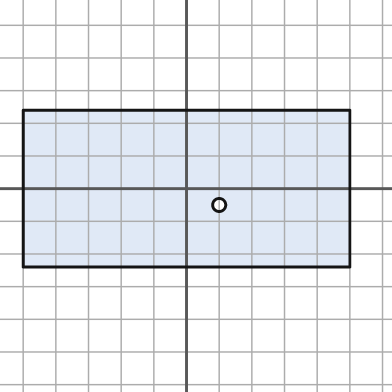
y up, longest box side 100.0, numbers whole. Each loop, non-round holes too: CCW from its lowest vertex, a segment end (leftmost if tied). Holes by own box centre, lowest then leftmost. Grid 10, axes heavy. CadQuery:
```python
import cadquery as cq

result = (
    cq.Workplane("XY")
    .moveTo(-50.0, -24.0)
    .lineTo(50.0, -24.0)
    .lineTo(50.0, 24.0)
    .lineTo(-50.0, 24.0)
    .close()
    .moveTo(10.0, -5.0)
    .circle(2.0)
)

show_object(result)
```